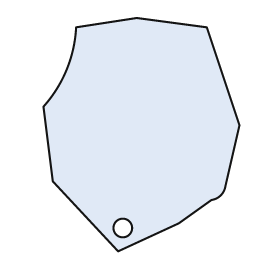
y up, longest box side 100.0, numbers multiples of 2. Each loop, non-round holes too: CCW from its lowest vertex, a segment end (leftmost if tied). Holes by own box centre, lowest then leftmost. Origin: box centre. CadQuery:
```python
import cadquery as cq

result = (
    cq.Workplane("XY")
    .moveTo(-10.0, -50.0)
    .lineTo(16.0, -38.0)
    .lineTo(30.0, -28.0)
    .threePointArc((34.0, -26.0), (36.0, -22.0))
    .lineTo(42.0, 4.0)
    .lineTo(28.0, 46.0)
    .lineTo(-2.0, 50.0)
    .lineTo(-28.0, 46.0)
    .threePointArc((-32.0, 28.0), (-42.0, 12.0))
    .lineTo(-38.0, -20.0)
    .close()
    .moveTo(-8.0, -40.0)
    .circle(4.0)
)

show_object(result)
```